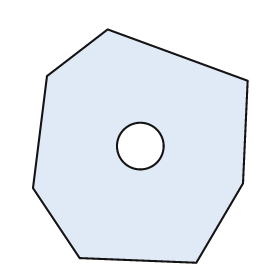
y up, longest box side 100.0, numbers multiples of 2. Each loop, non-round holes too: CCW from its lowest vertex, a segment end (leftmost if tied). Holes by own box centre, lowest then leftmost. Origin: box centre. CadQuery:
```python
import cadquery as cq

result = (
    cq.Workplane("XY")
    .moveTo(24.0, -50.0)
    .lineTo(44.0, -16.0)
    .lineTo(46.0, 28.0)
    .lineTo(-14.0, 50.0)
    .lineTo(-40.0, 30.0)
    .lineTo(-46.0, -18.0)
    .lineTo(-26.0, -48.0)
    .close()
    .moveTo(0.0, 0.0)
    .circle(10.0)
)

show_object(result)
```